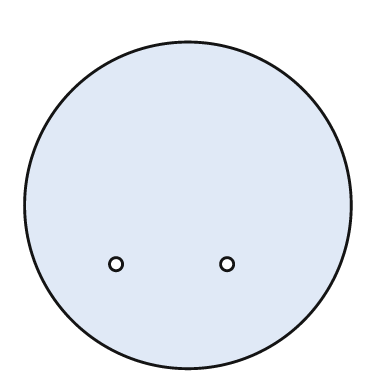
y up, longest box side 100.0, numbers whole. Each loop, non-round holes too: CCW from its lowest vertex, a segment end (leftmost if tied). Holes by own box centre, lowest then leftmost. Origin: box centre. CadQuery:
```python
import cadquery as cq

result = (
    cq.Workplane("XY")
    .moveTo(0.0, 0.0)
    .circle(50.0)
    .moveTo(-22.0, -18.0)
    .circle(2.0)
    .moveTo(12.0, -18.0)
    .circle(2.0)
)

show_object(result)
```